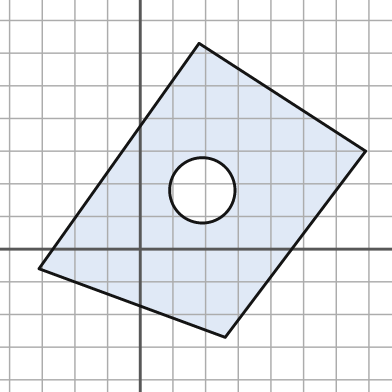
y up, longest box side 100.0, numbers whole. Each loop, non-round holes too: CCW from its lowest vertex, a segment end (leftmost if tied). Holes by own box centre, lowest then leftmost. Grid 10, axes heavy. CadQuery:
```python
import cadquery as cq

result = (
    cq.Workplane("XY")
    .moveTo(26.0, -27.0)
    .lineTo(69.0, 30.0)
    .lineTo(18.0, 63.0)
    .lineTo(-31.0, -6.0)
    .close()
    .moveTo(19.0, 18.0)
    .circle(10.0)
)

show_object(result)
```